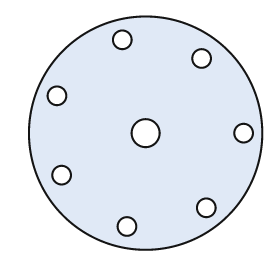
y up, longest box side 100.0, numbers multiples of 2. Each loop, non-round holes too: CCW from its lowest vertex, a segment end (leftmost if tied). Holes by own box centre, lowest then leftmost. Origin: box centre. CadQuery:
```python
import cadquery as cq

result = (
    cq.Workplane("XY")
    .moveTo(0.0, 0.0)
    .circle(50.0)
    .moveTo(-8.0, -40.0)
    .circle(4.0)
    .moveTo(26.0, -32.0)
    .circle(4.0)
    .moveTo(-36.0, -18.0)
    .circle(4.0)
    .moveTo(0.0, 0.0)
    .circle(6.0)
    .moveTo(42.0, 0.0)
    .circle(4.0)
    .moveTo(-38.0, 16.0)
    .circle(4.0)
    .moveTo(24.0, 32.0)
    .circle(4.0)
    .moveTo(-10.0, 40.0)
    .circle(4.0)
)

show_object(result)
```